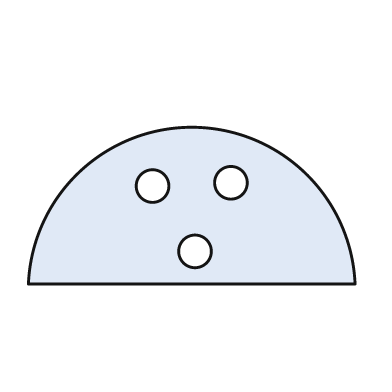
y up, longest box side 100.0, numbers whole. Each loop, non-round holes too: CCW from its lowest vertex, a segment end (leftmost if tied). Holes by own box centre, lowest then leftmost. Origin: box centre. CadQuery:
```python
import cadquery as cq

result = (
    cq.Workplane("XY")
    .moveTo(-50.0, -24.0)
    .lineTo(50.0, -24.0)
    .threePointArc((0.0, 24.0), (-50.0, -24.0))
    .close()
    .moveTo(1.0, -14.0)
    .circle(5.0)
    .moveTo(-12.0, 6.0)
    .circle(5.0)
    .moveTo(12.0, 7.0)
    .circle(5.0)
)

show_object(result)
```